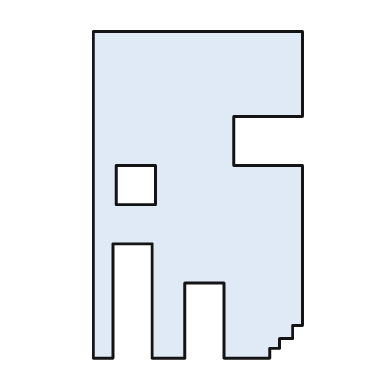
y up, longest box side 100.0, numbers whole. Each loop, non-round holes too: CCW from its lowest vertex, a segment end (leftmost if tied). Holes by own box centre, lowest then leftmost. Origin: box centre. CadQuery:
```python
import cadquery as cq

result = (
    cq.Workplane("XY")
    .moveTo(-32.0, -50.0)
    .lineTo(-26.0, -50.0)
    .lineTo(-26.0, -15.0)
    .lineTo(-14.0, -15.0)
    .lineTo(-14.0, -50.0)
    .lineTo(-4.0, -50.0)
    .lineTo(-4.0, -27.0)
    .lineTo(8.0, -27.0)
    .lineTo(8.0, -50.0)
    .lineTo(22.0, -50.0)
    .lineTo(22.0, -47.0)
    .lineTo(25.0, -47.0)
    .lineTo(25.0, -44.0)
    .lineTo(29.0, -44.0)
    .lineTo(29.0, -40.0)
    .lineTo(32.0, -40.0)
    .lineTo(32.0, 9.0)
    .lineTo(11.0, 9.0)
    .lineTo(11.0, 24.0)
    .lineTo(32.0, 24.0)
    .lineTo(32.0, 50.0)
    .lineTo(-32.0, 50.0)
    .close()
    .moveTo(-25.0, -3.0)
    .lineTo(-13.0, -3.0)
    .lineTo(-13.0, 9.0)
    .lineTo(-25.0, 9.0)
    .close()
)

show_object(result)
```